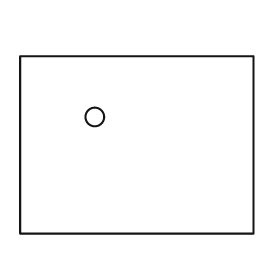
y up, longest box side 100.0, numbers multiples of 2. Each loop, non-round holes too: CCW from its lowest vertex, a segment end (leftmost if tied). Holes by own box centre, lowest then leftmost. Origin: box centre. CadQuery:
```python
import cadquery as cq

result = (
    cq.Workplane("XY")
    .moveTo(-50.0, -38.0)
    .lineTo(50.0, -38.0)
    .lineTo(50.0, 38.0)
    .lineTo(-50.0, 38.0)
    .close()
    .moveTo(-18.0, 12.0)
    .circle(4.0)
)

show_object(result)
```